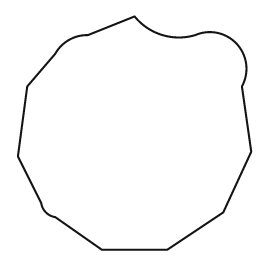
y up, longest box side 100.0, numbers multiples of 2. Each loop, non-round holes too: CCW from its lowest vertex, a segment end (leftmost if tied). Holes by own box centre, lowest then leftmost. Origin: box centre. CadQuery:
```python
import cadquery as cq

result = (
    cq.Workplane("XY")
    .moveTo(-14.0, -50.0)
    .lineTo(14.0, -50.0)
    .lineTo(38.0, -34.0)
    .lineTo(50.0, -8.0)
    .lineTo(46.0, 20.0)
    .threePointArc((44.0, 38.0), (26.0, 42.0))
    .threePointArc((12.0, 42.0), (0.0, 50.0))
    .lineTo(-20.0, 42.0)
    .threePointArc((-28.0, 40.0), (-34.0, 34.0))
    .lineTo(-46.0, 20.0)
    .lineTo(-50.0, -10.0)
    .lineTo(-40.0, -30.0)
    .threePointArc((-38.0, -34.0), (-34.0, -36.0))
    .close()
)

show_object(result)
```